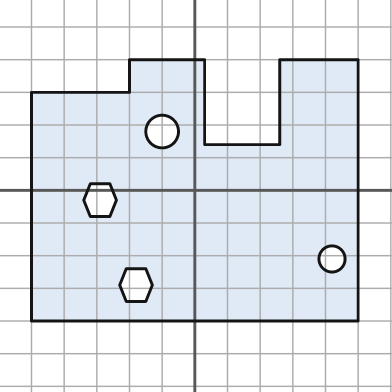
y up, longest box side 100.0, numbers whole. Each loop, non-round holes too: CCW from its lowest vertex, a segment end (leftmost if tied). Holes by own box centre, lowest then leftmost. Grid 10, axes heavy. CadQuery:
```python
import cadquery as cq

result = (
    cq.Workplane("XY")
    .moveTo(-50.0, -40.0)
    .lineTo(50.0, -40.0)
    .lineTo(50.0, 40.0)
    .lineTo(26.0, 40.0)
    .lineTo(26.0, 14.0)
    .lineTo(3.0, 14.0)
    .lineTo(3.0, 40.0)
    .lineTo(-20.0, 40.0)
    .lineTo(-20.0, 30.0)
    .lineTo(-50.0, 30.0)
    .close()
    .moveTo(-21.0, -34.0)
    .lineTo(-15.0, -34.0)
    .lineTo(-13.0, -29.0)
    .lineTo(-15.0, -24.0)
    .lineTo(-21.0, -24.0)
    .lineTo(-23.0, -29.0)
    .close()
    .moveTo(42.0, -21.0)
    .circle(4.0)
    .moveTo(-32.0, -8.0)
    .lineTo(-26.0, -8.0)
    .lineTo(-24.0, -3.0)
    .lineTo(-26.0, 2.0)
    .lineTo(-32.0, 2.0)
    .lineTo(-34.0, -3.0)
    .close()
    .moveTo(-10.0, 18.0)
    .circle(5.0)
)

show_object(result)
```